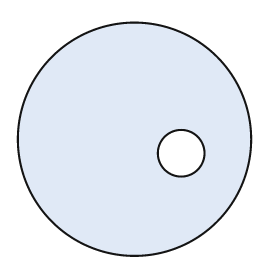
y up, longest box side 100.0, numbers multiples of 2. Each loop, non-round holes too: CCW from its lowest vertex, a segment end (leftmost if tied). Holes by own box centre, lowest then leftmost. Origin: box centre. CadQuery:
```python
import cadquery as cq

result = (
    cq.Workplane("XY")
    .moveTo(0.0, 0.0)
    .circle(50.0)
    .moveTo(20.0, -6.0)
    .circle(10.0)
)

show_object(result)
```